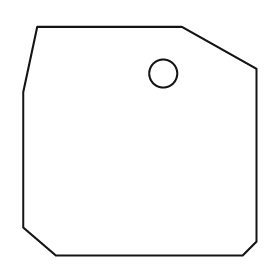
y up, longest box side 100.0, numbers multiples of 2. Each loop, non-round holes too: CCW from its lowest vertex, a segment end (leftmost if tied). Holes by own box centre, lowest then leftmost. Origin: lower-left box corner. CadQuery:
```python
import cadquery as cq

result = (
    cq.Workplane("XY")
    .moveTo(14.0, 0.0)
    .lineTo(94.0, 0.0)
    .lineTo(100.0, 6.0)
    .lineTo(100.0, 80.0)
    .lineTo(68.0, 98.0)
    .lineTo(6.0, 98.0)
    .lineTo(0.0, 70.0)
    .lineTo(0.0, 12.0)
    .close()
    .moveTo(60.0, 78.0)
    .circle(6.0)
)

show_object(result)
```